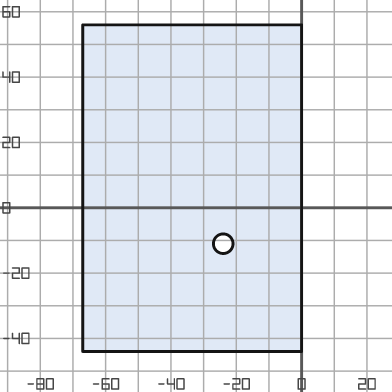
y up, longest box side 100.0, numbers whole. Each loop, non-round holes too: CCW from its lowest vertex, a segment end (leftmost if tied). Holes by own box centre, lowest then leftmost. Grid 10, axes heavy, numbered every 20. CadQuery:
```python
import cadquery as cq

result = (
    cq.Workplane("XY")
    .moveTo(-67.0, -44.0)
    .lineTo(0.0, -44.0)
    .lineTo(0.0, 56.0)
    .lineTo(-67.0, 56.0)
    .close()
    .moveTo(-24.0, -11.0)
    .circle(3.0)
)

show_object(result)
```